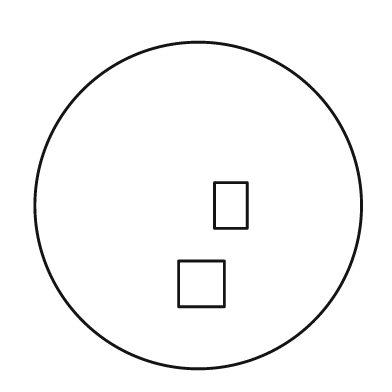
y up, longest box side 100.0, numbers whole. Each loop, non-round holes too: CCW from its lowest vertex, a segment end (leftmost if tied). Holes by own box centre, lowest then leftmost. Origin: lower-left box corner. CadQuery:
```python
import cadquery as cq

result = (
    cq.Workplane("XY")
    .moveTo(50.0, 50.0)
    .circle(50.0)
    .moveTo(44.0, 19.0)
    .lineTo(58.0, 19.0)
    .lineTo(58.0, 33.0)
    .lineTo(44.0, 33.0)
    .close()
    .moveTo(55.0, 43.0)
    .lineTo(65.0, 43.0)
    .lineTo(65.0, 57.0)
    .lineTo(55.0, 57.0)
    .close()
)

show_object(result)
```